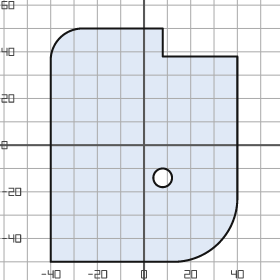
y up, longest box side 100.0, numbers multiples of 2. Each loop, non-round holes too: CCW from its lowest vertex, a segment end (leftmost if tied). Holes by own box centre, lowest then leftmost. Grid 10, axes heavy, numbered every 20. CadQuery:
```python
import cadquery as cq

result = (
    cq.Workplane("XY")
    .moveTo(-40.0, -50.0)
    .lineTo(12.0, -50.0)
    .threePointArc((32.0, -42.0), (40.0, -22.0))
    .lineTo(40.0, 38.0)
    .lineTo(8.0, 38.0)
    .lineTo(8.0, 50.0)
    .lineTo(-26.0, 50.0)
    .threePointArc((-36.0, 46.0), (-40.0, 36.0))
    .close()
    .moveTo(8.0, -14.0)
    .circle(4.0)
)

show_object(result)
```